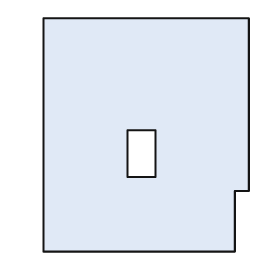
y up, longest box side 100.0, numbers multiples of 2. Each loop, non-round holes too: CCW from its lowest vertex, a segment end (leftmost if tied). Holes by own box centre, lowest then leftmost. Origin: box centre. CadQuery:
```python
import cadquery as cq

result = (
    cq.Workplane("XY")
    .moveTo(-44.0, -50.0)
    .lineTo(38.0, -50.0)
    .lineTo(38.0, -24.0)
    .lineTo(44.0, -24.0)
    .lineTo(44.0, 50.0)
    .lineTo(-44.0, 50.0)
    .close()
    .moveTo(-8.0, -18.0)
    .lineTo(4.0, -18.0)
    .lineTo(4.0, 2.0)
    .lineTo(-8.0, 2.0)
    .close()
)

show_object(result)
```